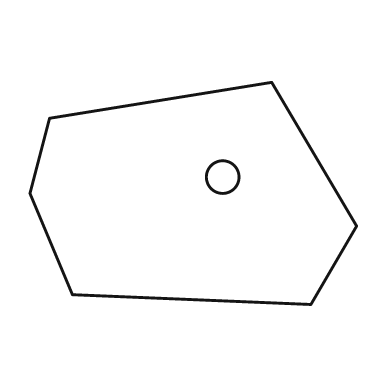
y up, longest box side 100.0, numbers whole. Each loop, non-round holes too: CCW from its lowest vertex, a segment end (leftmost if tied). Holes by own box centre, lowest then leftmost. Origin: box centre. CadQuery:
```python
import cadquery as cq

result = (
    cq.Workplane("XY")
    .moveTo(36.0, -34.0)
    .lineTo(50.0, -10.0)
    .lineTo(24.0, 34.0)
    .lineTo(-44.0, 23.0)
    .lineTo(-50.0, 0.0)
    .lineTo(-37.0, -31.0)
    .close()
    .moveTo(9.0, 5.0)
    .circle(5.0)
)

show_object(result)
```